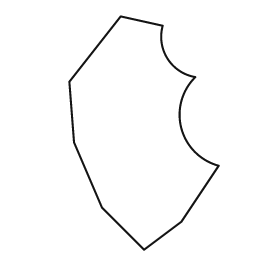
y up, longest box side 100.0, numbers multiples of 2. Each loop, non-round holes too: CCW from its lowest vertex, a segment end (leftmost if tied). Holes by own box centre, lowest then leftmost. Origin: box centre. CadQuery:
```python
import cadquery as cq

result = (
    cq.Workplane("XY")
    .moveTo(0.0, -50.0)
    .lineTo(16.0, -38.0)
    .lineTo(32.0, -14.0)
    .threePointArc((16.0, 2.0), (22.0, 24.0))
    .threePointArc((10.0, 32.0), (8.0, 46.0))
    .lineTo(-10.0, 50.0)
    .lineTo(-32.0, 22.0)
    .lineTo(-30.0, -4.0)
    .lineTo(-18.0, -32.0)
    .close()
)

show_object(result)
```